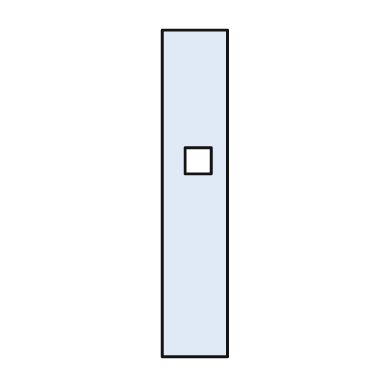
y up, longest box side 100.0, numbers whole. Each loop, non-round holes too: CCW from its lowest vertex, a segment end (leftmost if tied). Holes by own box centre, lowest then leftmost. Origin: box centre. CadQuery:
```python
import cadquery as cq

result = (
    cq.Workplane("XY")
    .moveTo(-10.0, -50.0)
    .lineTo(10.0, -50.0)
    .lineTo(10.0, 50.0)
    .lineTo(-10.0, 50.0)
    .close()
    .moveTo(-3.0, 6.0)
    .lineTo(5.0, 6.0)
    .lineTo(5.0, 14.0)
    .lineTo(-3.0, 14.0)
    .close()
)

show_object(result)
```